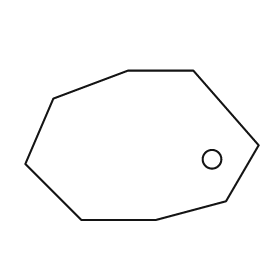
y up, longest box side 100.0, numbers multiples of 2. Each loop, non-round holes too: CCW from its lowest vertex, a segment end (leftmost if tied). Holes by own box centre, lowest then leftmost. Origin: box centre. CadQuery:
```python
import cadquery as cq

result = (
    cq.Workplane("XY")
    .moveTo(-26.0, -32.0)
    .lineTo(6.0, -32.0)
    .lineTo(36.0, -24.0)
    .lineTo(50.0, 0.0)
    .lineTo(22.0, 32.0)
    .lineTo(-6.0, 32.0)
    .lineTo(-38.0, 20.0)
    .lineTo(-50.0, -8.0)
    .close()
    .moveTo(30.0, -6.0)
    .circle(4.0)
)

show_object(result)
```